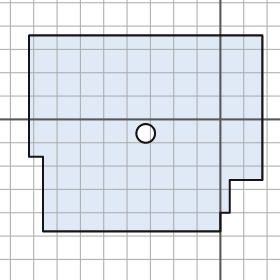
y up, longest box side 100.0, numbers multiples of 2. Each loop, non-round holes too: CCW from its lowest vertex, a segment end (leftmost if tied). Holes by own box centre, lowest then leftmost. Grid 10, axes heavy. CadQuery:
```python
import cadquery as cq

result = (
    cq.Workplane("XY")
    .moveTo(-76.0, -48.0)
    .lineTo(0.0, -48.0)
    .lineTo(0.0, -40.0)
    .lineTo(4.0, -40.0)
    .lineTo(4.0, -26.0)
    .lineTo(18.0, -26.0)
    .lineTo(18.0, 36.0)
    .lineTo(-82.0, 36.0)
    .lineTo(-82.0, -16.0)
    .lineTo(-76.0, -16.0)
    .close()
    .moveTo(-32.0, -6.0)
    .circle(4.0)
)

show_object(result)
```